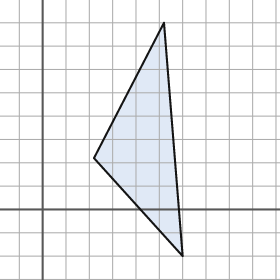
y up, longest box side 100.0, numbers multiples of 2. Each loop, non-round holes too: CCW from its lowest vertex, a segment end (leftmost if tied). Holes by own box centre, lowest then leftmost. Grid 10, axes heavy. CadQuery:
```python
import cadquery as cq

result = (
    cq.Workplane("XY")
    .moveTo(60.0, -20.0)
    .lineTo(52.0, 80.0)
    .lineTo(22.0, 22.0)
    .close()
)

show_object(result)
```